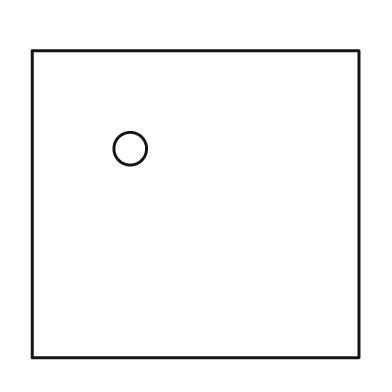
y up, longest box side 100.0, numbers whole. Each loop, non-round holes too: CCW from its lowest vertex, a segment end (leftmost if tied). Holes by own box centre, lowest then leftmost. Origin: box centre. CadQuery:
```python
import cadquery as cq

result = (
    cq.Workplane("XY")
    .moveTo(-50.0, -47.0)
    .lineTo(50.0, -47.0)
    .lineTo(50.0, 47.0)
    .lineTo(-50.0, 47.0)
    .close()
    .moveTo(-20.0, 17.0)
    .circle(5.0)
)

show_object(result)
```